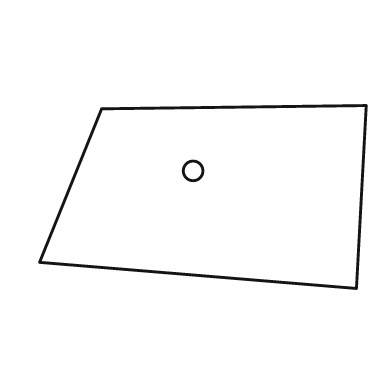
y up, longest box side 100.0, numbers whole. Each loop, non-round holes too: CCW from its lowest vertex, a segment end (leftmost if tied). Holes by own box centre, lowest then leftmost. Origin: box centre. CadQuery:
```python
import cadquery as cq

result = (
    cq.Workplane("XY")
    .moveTo(47.0, -28.0)
    .lineTo(50.0, 28.0)
    .lineTo(-31.0, 27.0)
    .lineTo(-50.0, -20.0)
    .close()
    .moveTo(-3.0, 8.0)
    .circle(3.0)
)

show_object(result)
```